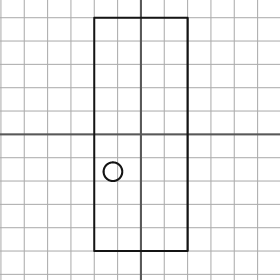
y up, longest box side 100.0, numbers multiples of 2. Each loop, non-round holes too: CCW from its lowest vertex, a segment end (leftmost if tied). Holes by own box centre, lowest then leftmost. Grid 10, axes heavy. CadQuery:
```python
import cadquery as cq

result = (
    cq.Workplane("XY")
    .moveTo(-20.0, -50.0)
    .lineTo(20.0, -50.0)
    .lineTo(20.0, 50.0)
    .lineTo(-20.0, 50.0)
    .close()
    .moveTo(-12.0, -16.0)
    .circle(4.0)
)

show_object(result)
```